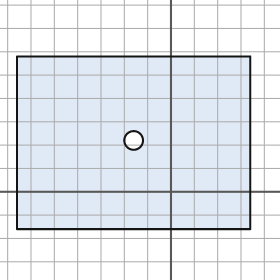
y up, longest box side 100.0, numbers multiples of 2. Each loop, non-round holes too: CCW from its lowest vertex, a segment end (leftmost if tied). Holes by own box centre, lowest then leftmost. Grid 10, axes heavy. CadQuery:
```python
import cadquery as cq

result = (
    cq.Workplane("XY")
    .moveTo(-66.0, -16.0)
    .lineTo(34.0, -16.0)
    .lineTo(34.0, 58.0)
    .lineTo(-66.0, 58.0)
    .close()
    .moveTo(-16.0, 22.0)
    .circle(4.0)
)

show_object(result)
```